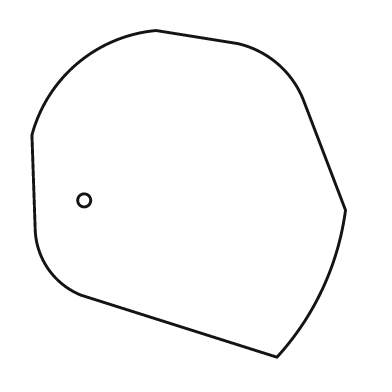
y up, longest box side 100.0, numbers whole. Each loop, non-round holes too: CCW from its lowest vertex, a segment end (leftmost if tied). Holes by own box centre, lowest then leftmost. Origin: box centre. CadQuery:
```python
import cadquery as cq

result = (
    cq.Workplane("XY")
    .moveTo(27.0, -50.0)
    .threePointArc((41.0, -29.0), (48.0, -5.0))
    .lineTo(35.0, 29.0)
    .threePointArc((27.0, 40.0), (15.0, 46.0))
    .lineTo(-10.0, 50.0)
    .threePointArc((-34.0, 40.0), (-48.0, 18.0))
    .lineTo(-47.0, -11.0)
    .threePointArc((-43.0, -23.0), (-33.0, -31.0))
    .close()
    .moveTo(-32.0, -2.0)
    .circle(2.0)
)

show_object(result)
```